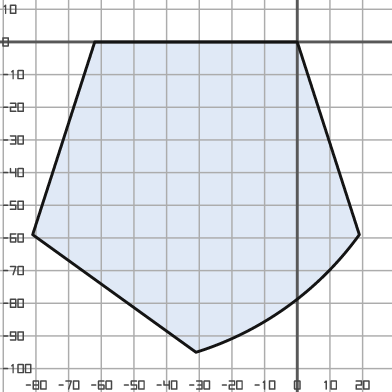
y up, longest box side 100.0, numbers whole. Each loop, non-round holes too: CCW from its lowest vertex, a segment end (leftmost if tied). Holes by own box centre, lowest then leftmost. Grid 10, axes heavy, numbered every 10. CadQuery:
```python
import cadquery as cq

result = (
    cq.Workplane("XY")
    .moveTo(-31.0, -95.0)
    .threePointArc((-3.0, -81.0), (19.0, -59.0))
    .lineTo(0.0, 0.0)
    .lineTo(-62.0, 0.0)
    .lineTo(-81.0, -59.0)
    .close()
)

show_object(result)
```